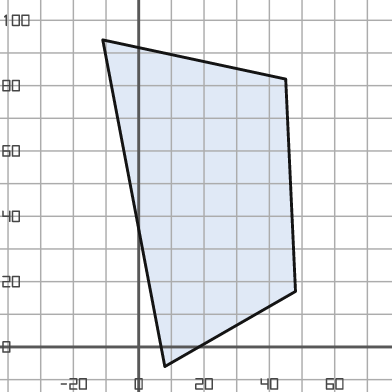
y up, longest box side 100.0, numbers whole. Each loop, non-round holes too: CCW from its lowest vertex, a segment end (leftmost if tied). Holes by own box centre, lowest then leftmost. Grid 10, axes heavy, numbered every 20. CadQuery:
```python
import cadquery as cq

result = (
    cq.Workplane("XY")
    .moveTo(8.0, -6.0)
    .lineTo(48.0, 17.0)
    .lineTo(45.0, 82.0)
    .lineTo(-11.0, 94.0)
    .close()
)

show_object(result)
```